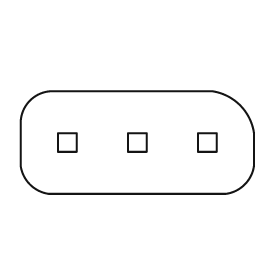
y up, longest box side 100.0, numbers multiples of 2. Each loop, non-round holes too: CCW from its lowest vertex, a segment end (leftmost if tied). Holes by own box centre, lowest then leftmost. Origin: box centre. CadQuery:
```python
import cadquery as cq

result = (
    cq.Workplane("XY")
    .moveTo(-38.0, -22.0)
    .lineTo(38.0, -22.0)
    .threePointArc((46.0, -18.0), (50.0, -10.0))
    .lineTo(50.0, 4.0)
    .threePointArc((44.0, 16.0), (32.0, 22.0))
    .lineTo(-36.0, 22.0)
    .threePointArc((-46.0, 18.0), (-50.0, 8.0))
    .lineTo(-50.0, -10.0)
    .threePointArc((-46.0, -18.0), (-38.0, -22.0))
    .close()
    .moveTo(-34.0, -4.0)
    .lineTo(-26.0, -4.0)
    .lineTo(-26.0, 4.0)
    .lineTo(-34.0, 4.0)
    .close()
    .moveTo(-4.0, -4.0)
    .lineTo(4.0, -4.0)
    .lineTo(4.0, 4.0)
    .lineTo(-4.0, 4.0)
    .close()
    .moveTo(26.0, -4.0)
    .lineTo(34.0, -4.0)
    .lineTo(34.0, 4.0)
    .lineTo(26.0, 4.0)
    .close()
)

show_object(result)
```